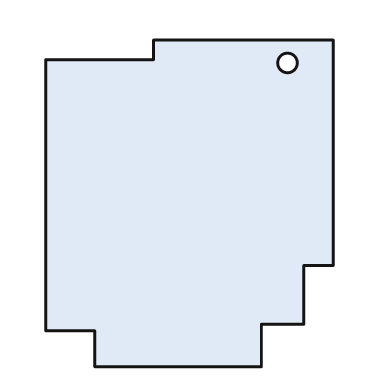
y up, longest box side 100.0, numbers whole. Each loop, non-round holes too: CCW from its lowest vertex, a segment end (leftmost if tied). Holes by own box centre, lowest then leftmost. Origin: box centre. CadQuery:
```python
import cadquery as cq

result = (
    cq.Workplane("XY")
    .moveTo(-29.0, -50.0)
    .lineTo(22.0, -50.0)
    .lineTo(22.0, -37.0)
    .lineTo(35.0, -37.0)
    .lineTo(35.0, -19.0)
    .lineTo(44.0, -19.0)
    .lineTo(44.0, 50.0)
    .lineTo(-11.0, 50.0)
    .lineTo(-11.0, 44.0)
    .lineTo(-44.0, 44.0)
    .lineTo(-44.0, -39.0)
    .lineTo(-29.0, -39.0)
    .close()
    .moveTo(30.0, 43.0)
    .circle(3.0)
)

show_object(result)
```